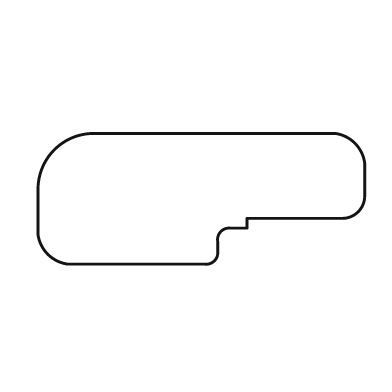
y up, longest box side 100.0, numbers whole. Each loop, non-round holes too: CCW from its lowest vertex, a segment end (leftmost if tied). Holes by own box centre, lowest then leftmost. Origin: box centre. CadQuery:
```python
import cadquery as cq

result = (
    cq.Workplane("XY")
    .moveTo(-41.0, -20.0)
    .lineTo(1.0, -20.0)
    .threePointArc((4.0, -19.0), (5.0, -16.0))
    .lineTo(5.0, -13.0)
    .threePointArc((6.0, -10.0), (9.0, -9.0))
    .lineTo(14.0, -9.0)
    .lineTo(14.0, -6.0)
    .lineTo(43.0, -6.0)
    .threePointArc((48.0, -4.0), (50.0, 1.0))
    .lineTo(50.0, 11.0)
    .threePointArc((47.0, 17.0), (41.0, 20.0))
    .lineTo(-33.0, 20.0)
    .threePointArc((-45.0, 15.0), (-50.0, 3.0))
    .lineTo(-50.0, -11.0)
    .threePointArc((-47.0, -17.0), (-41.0, -20.0))
    .close()
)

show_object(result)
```